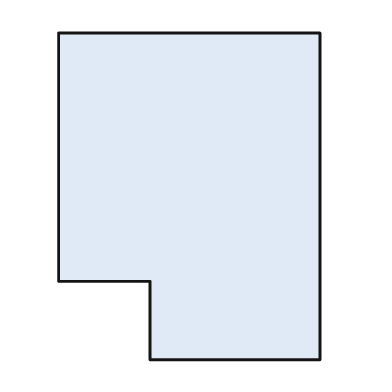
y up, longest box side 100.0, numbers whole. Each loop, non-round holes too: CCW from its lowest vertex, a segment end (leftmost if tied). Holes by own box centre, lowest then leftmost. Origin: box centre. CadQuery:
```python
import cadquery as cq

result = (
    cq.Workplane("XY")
    .moveTo(-12.0, -50.0)
    .lineTo(40.0, -50.0)
    .lineTo(40.0, 50.0)
    .lineTo(-40.0, 50.0)
    .lineTo(-40.0, -26.0)
    .lineTo(-12.0, -26.0)
    .close()
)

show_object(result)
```